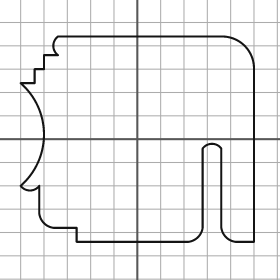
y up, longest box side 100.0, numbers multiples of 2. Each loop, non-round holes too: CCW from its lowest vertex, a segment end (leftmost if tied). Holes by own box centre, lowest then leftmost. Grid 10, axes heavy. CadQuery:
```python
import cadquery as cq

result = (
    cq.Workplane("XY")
    .moveTo(-26.0, -44.0)
    .lineTo(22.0, -44.0)
    .threePointArc((26.0, -42.0), (28.0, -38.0))
    .lineTo(28.0, -4.0)
    .threePointArc((32.0, -2.0), (36.0, -4.0))
    .lineTo(36.0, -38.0)
    .threePointArc((38.0, -42.0), (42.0, -44.0))
    .lineTo(50.0, -44.0)
    .lineTo(50.0, 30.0)
    .threePointArc((46.0, 40.0), (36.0, 44.0))
    .lineTo(-34.0, 44.0)
    .threePointArc((-36.0, 40.0), (-34.0, 36.0))
    .lineTo(-40.0, 36.0)
    .lineTo(-40.0, 30.0)
    .lineTo(-44.0, 30.0)
    .lineTo(-44.0, 24.0)
    .lineTo(-50.0, 24.0)
    .threePointArc((-40.0, 2.0), (-50.0, -20.0))
    .threePointArc((-46.0, -22.0), (-42.0, -20.0))
    .lineTo(-42.0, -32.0)
    .threePointArc((-40.0, -36.0), (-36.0, -38.0))
    .lineTo(-26.0, -38.0)
    .close()
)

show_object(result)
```